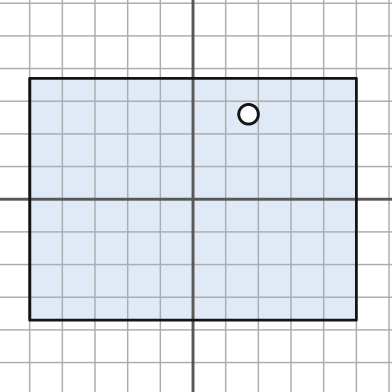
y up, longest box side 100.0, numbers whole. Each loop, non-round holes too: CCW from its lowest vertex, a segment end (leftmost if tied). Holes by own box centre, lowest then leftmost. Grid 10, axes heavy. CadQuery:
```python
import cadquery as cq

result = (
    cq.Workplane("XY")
    .moveTo(-50.0, -37.0)
    .lineTo(50.0, -37.0)
    .lineTo(50.0, 37.0)
    .lineTo(-50.0, 37.0)
    .close()
    .moveTo(17.0, 26.0)
    .circle(3.0)
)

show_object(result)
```